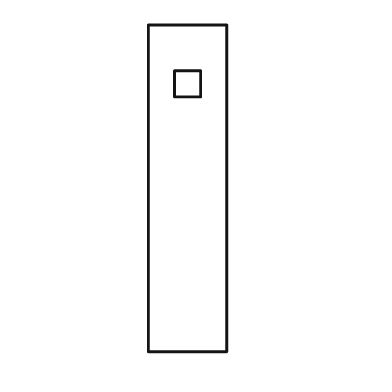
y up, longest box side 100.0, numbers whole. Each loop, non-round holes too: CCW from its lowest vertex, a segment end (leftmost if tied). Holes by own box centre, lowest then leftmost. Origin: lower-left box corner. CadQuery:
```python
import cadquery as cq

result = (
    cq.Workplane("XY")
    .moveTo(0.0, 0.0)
    .lineTo(24.0, 0.0)
    .lineTo(24.0, 100.0)
    .lineTo(0.0, 100.0)
    .close()
    .moveTo(8.0, 78.0)
    .lineTo(16.0, 78.0)
    .lineTo(16.0, 86.0)
    .lineTo(8.0, 86.0)
    .close()
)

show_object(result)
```